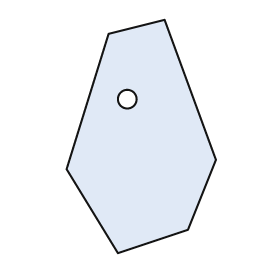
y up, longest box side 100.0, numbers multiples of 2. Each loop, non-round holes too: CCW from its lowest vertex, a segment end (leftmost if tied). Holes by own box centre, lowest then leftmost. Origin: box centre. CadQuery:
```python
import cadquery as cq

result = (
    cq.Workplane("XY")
    .moveTo(-10.0, -50.0)
    .lineTo(20.0, -40.0)
    .lineTo(32.0, -10.0)
    .lineTo(10.0, 50.0)
    .lineTo(-14.0, 44.0)
    .lineTo(-32.0, -14.0)
    .close()
    .moveTo(-6.0, 16.0)
    .circle(4.0)
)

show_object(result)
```